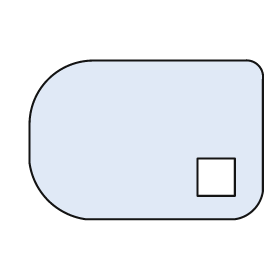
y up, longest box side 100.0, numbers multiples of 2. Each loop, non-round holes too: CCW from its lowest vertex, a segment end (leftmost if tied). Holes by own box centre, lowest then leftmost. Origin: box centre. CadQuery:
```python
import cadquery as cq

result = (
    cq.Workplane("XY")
    .moveTo(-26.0, -34.0)
    .lineTo(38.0, -34.0)
    .threePointArc((46.0, -30.0), (50.0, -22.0))
    .lineTo(50.0, 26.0)
    .threePointArc((48.0, 32.0), (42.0, 34.0))
    .lineTo(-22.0, 34.0)
    .threePointArc((-42.0, 26.0), (-50.0, 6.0))
    .lineTo(-50.0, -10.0)
    .threePointArc((-42.0, -26.0), (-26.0, -34.0))
    .close()
    .moveTo(22.0, -24.0)
    .lineTo(38.0, -24.0)
    .lineTo(38.0, -8.0)
    .lineTo(22.0, -8.0)
    .close()
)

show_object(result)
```